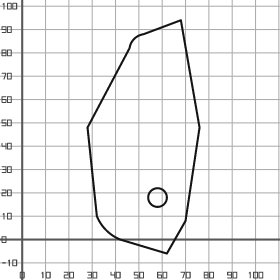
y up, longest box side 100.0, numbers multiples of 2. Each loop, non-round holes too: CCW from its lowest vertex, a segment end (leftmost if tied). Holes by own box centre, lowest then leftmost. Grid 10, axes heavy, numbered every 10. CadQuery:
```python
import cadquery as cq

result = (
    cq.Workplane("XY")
    .moveTo(62.0, -6.0)
    .lineTo(70.0, 8.0)
    .lineTo(76.0, 48.0)
    .lineTo(68.0, 94.0)
    .lineTo(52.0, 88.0)
    .threePointArc((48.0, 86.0), (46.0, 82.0))
    .lineTo(28.0, 48.0)
    .lineTo(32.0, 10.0)
    .threePointArc((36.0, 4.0), (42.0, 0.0))
    .close()
    .moveTo(58.0, 18.0)
    .circle(4.0)
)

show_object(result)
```